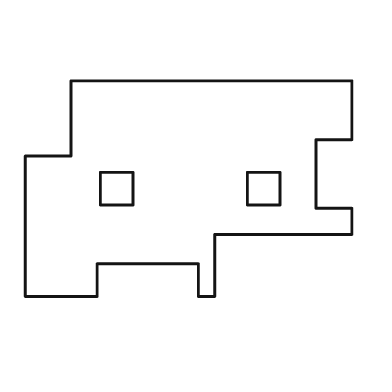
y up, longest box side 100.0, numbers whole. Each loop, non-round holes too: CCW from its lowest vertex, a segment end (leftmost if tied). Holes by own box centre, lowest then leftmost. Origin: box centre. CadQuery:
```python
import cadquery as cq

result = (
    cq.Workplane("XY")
    .moveTo(-50.0, -33.0)
    .lineTo(-28.0, -33.0)
    .lineTo(-28.0, -23.0)
    .lineTo(3.0, -23.0)
    .lineTo(3.0, -33.0)
    .lineTo(8.0, -33.0)
    .lineTo(8.0, -14.0)
    .lineTo(50.0, -14.0)
    .lineTo(50.0, -6.0)
    .lineTo(39.0, -6.0)
    .lineTo(39.0, 15.0)
    .lineTo(50.0, 15.0)
    .lineTo(50.0, 33.0)
    .lineTo(-36.0, 33.0)
    .lineTo(-36.0, 10.0)
    .lineTo(-50.0, 10.0)
    .close()
    .moveTo(-27.0, -5.0)
    .lineTo(-17.0, -5.0)
    .lineTo(-17.0, 5.0)
    .lineTo(-27.0, 5.0)
    .close()
    .moveTo(18.0, -5.0)
    .lineTo(28.0, -5.0)
    .lineTo(28.0, 5.0)
    .lineTo(18.0, 5.0)
    .close()
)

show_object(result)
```